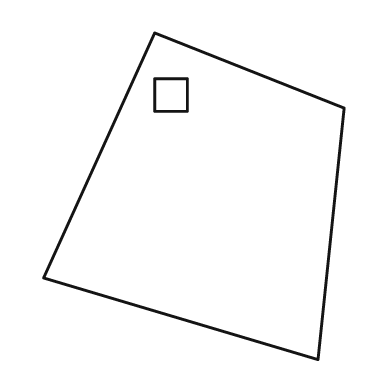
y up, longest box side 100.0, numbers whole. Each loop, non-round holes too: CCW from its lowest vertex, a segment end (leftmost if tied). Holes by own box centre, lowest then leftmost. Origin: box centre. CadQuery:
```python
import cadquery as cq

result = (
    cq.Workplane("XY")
    .moveTo(38.0, -50.0)
    .lineTo(46.0, 27.0)
    .lineTo(-12.0, 50.0)
    .lineTo(-46.0, -25.0)
    .close()
    .moveTo(-12.0, 26.0)
    .lineTo(-2.0, 26.0)
    .lineTo(-2.0, 36.0)
    .lineTo(-12.0, 36.0)
    .close()
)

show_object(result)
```